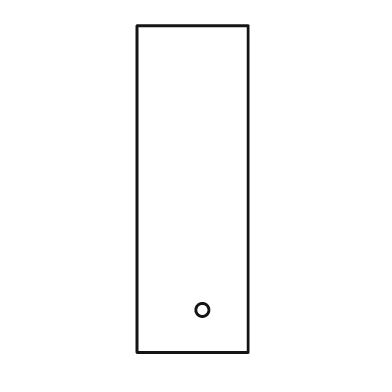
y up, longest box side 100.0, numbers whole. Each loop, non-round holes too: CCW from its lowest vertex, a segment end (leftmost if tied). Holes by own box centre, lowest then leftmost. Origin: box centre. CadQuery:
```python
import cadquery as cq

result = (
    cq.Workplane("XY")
    .moveTo(-17.0, -50.0)
    .lineTo(17.0, -50.0)
    .lineTo(17.0, 50.0)
    .lineTo(-17.0, 50.0)
    .close()
    .moveTo(3.0, -37.0)
    .circle(2.0)
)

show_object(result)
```